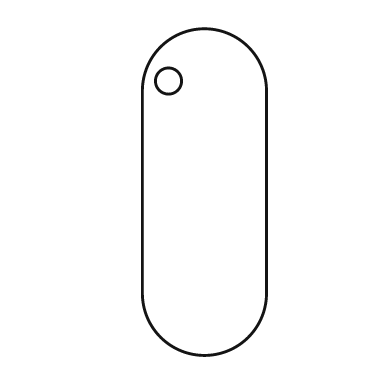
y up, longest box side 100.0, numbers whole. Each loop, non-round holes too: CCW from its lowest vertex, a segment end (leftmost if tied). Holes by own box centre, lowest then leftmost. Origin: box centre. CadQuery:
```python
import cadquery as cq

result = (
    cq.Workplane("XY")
    .moveTo(-19.0, -31.0)
    .threePointArc((0.0, -50.0), (19.0, -31.0))
    .lineTo(19.0, 31.0)
    .threePointArc((0.0, 50.0), (-19.0, 31.0))
    .close()
    .moveTo(-11.0, 34.0)
    .circle(4.0)
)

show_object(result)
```